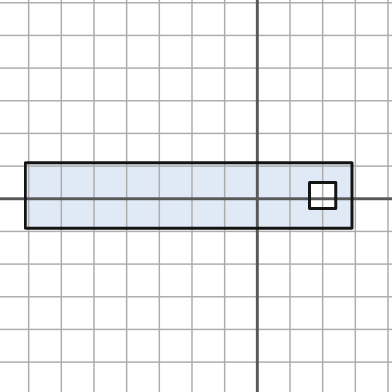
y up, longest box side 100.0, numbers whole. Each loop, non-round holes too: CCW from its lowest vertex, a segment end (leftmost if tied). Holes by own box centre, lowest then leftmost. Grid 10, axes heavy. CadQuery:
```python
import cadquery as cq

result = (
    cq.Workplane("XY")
    .moveTo(-71.0, -9.0)
    .lineTo(29.0, -9.0)
    .lineTo(29.0, 11.0)
    .lineTo(-71.0, 11.0)
    .close()
    .moveTo(16.0, -3.0)
    .lineTo(24.0, -3.0)
    .lineTo(24.0, 5.0)
    .lineTo(16.0, 5.0)
    .close()
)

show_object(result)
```